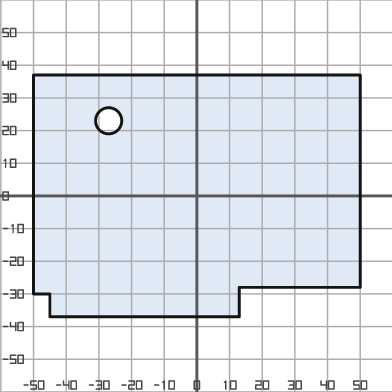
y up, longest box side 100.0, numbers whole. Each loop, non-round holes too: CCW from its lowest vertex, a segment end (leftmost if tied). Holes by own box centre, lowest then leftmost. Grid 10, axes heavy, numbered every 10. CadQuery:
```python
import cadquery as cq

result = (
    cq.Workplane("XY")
    .moveTo(-45.0, -37.0)
    .lineTo(13.0, -37.0)
    .lineTo(13.0, -28.0)
    .lineTo(50.0, -28.0)
    .lineTo(50.0, 37.0)
    .lineTo(-50.0, 37.0)
    .lineTo(-50.0, -30.0)
    .lineTo(-45.0, -30.0)
    .close()
    .moveTo(-27.0, 23.0)
    .circle(4.0)
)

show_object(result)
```